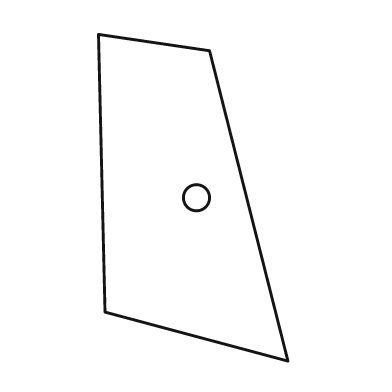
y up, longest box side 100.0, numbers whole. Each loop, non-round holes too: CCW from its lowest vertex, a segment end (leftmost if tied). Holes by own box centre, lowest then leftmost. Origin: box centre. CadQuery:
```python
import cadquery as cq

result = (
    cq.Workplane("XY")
    .moveTo(29.0, -50.0)
    .lineTo(5.0, 45.0)
    .lineTo(-29.0, 50.0)
    .lineTo(-27.0, -35.0)
    .close()
    .moveTo(1.0, 0.0)
    .circle(4.0)
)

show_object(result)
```